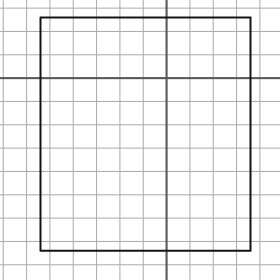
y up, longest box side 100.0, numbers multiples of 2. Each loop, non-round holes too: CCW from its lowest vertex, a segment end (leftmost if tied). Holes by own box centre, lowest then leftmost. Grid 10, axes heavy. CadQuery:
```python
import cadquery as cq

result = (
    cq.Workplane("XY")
    .moveTo(-54.0, -74.0)
    .lineTo(36.0, -74.0)
    .lineTo(36.0, 26.0)
    .lineTo(-54.0, 26.0)
    .close()
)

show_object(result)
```